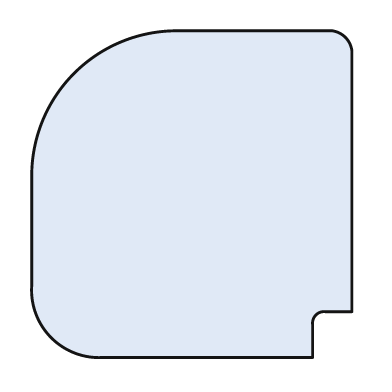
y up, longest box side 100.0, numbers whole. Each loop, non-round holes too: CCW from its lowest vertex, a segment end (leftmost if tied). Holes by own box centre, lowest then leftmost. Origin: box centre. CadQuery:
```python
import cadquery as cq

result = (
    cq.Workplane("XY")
    .moveTo(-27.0, -50.0)
    .lineTo(37.0, -50.0)
    .lineTo(37.0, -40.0)
    .threePointArc((38.0, -37.0), (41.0, -36.0))
    .lineTo(49.0, -36.0)
    .lineTo(49.0, 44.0)
    .threePointArc((47.0, 48.0), (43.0, 50.0))
    .lineTo(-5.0, 50.0)
    .threePointArc((-36.0, 37.0), (-49.0, 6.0))
    .lineTo(-49.0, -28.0)
    .threePointArc((-43.0, -44.0), (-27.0, -50.0))
    .close()
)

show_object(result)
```